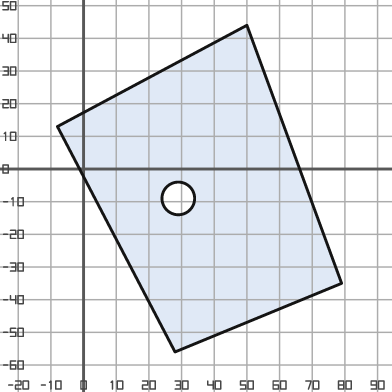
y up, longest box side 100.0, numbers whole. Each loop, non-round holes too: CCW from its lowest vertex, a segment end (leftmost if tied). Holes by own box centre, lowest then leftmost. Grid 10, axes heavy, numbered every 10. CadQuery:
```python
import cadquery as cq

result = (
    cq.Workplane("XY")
    .moveTo(28.0, -56.0)
    .lineTo(79.0, -35.0)
    .lineTo(50.0, 44.0)
    .lineTo(-8.0, 13.0)
    .close()
    .moveTo(29.0, -9.0)
    .circle(5.0)
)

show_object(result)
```